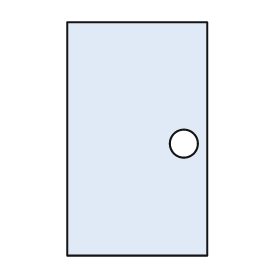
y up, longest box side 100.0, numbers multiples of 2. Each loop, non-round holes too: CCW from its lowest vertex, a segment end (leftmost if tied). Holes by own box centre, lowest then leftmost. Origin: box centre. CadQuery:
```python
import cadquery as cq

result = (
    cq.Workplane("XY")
    .moveTo(-30.0, -50.0)
    .lineTo(30.0, -50.0)
    .lineTo(30.0, 50.0)
    .lineTo(-30.0, 50.0)
    .close()
    .moveTo(20.0, -2.0)
    .circle(6.0)
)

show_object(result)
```